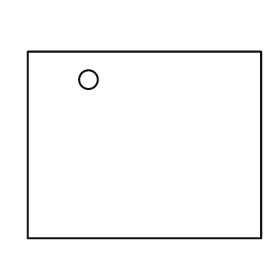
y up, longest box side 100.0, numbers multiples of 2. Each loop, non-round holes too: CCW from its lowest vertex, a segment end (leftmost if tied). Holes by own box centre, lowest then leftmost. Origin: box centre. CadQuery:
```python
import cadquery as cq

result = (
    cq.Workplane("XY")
    .moveTo(-50.0, -40.0)
    .lineTo(50.0, -40.0)
    .lineTo(50.0, 40.0)
    .lineTo(-50.0, 40.0)
    .close()
    .moveTo(-24.0, 28.0)
    .circle(4.0)
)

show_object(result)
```